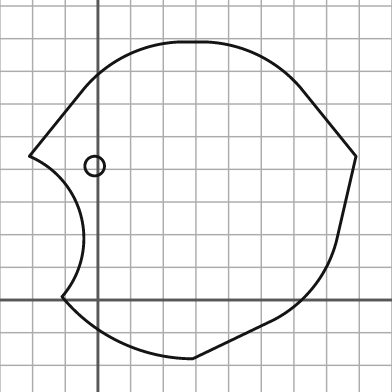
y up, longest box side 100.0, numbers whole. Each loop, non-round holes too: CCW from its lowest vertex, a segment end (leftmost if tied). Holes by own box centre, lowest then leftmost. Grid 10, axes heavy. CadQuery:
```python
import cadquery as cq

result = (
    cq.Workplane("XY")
    .moveTo(29.0, -18.0)
    .lineTo(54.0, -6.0)
    .threePointArc((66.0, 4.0), (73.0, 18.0))
    .lineTo(79.0, 44.0)
    .lineTo(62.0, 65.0)
    .threePointArc((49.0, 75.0), (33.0, 79.0))
    .lineTo(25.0, 79.0)
    .threePointArc((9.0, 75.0), (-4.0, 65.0))
    .lineTo(-21.0, 44.0)
    .threePointArc((-5.0, 25.0), (-11.0, 1.0))
    .threePointArc((7.0, -13.0), (29.0, -18.0))
    .close()
    .moveTo(-1.0, 41.0)
    .circle(3.0)
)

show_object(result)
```